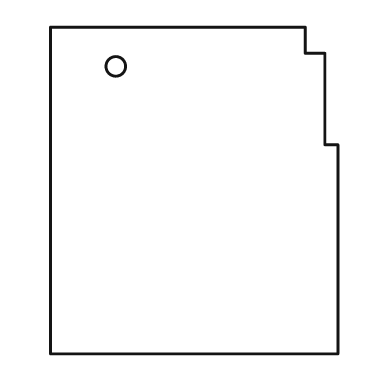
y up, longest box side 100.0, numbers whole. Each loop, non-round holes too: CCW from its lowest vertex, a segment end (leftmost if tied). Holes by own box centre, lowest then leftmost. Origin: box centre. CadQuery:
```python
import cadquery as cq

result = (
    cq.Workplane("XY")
    .moveTo(-44.0, -50.0)
    .lineTo(44.0, -50.0)
    .lineTo(44.0, 14.0)
    .lineTo(40.0, 14.0)
    .lineTo(40.0, 42.0)
    .lineTo(34.0, 42.0)
    .lineTo(34.0, 50.0)
    .lineTo(-44.0, 50.0)
    .close()
    .moveTo(-24.0, 38.0)
    .circle(3.0)
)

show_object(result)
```